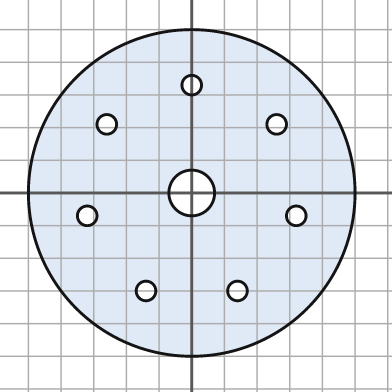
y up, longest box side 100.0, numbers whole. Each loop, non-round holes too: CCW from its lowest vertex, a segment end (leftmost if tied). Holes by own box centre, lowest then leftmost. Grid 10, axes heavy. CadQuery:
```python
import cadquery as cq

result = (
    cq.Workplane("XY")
    .moveTo(0.0, 0.0)
    .circle(50.0)
    .moveTo(-14.0, -30.0)
    .circle(3.0)
    .moveTo(14.0, -30.0)
    .circle(3.0)
    .moveTo(-32.0, -7.0)
    .circle(3.0)
    .moveTo(32.0, -7.0)
    .circle(3.0)
    .moveTo(0.0, 0.0)
    .circle(7.0)
    .moveTo(-26.0, 21.0)
    .circle(3.0)
    .moveTo(26.0, 21.0)
    .circle(3.0)
    .moveTo(0.0, 33.0)
    .circle(3.0)
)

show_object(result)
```